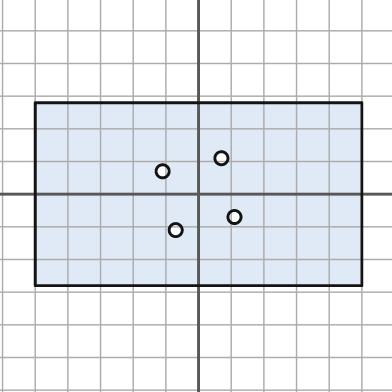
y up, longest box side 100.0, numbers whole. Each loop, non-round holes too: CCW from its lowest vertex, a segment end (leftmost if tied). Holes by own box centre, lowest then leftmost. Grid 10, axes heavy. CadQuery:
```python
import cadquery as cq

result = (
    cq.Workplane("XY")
    .moveTo(-50.0, -28.0)
    .lineTo(50.0, -28.0)
    .lineTo(50.0, 28.0)
    .lineTo(-50.0, 28.0)
    .close()
    .moveTo(-7.0, -11.0)
    .circle(2.0)
    .moveTo(11.0, -7.0)
    .circle(2.0)
    .moveTo(-11.0, 7.0)
    .circle(2.0)
    .moveTo(7.0, 11.0)
    .circle(2.0)
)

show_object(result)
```